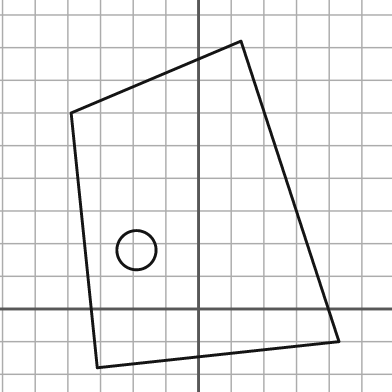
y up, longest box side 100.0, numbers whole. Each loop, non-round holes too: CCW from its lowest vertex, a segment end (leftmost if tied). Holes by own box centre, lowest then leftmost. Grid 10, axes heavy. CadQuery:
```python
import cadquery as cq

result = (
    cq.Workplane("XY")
    .moveTo(-31.0, -18.0)
    .lineTo(43.0, -10.0)
    .lineTo(13.0, 82.0)
    .lineTo(-39.0, 60.0)
    .close()
    .moveTo(-19.0, 18.0)
    .circle(6.0)
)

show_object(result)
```